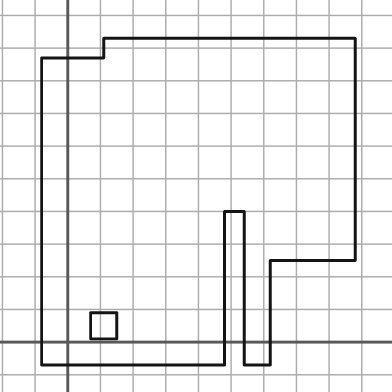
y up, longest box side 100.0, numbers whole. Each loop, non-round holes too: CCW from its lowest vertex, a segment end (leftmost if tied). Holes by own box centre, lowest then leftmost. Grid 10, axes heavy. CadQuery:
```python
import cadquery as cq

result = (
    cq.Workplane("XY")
    .moveTo(-8.0, -7.0)
    .lineTo(48.0, -7.0)
    .lineTo(48.0, 40.0)
    .lineTo(54.0, 40.0)
    .lineTo(54.0, -7.0)
    .lineTo(62.0, -7.0)
    .lineTo(62.0, 25.0)
    .lineTo(88.0, 25.0)
    .lineTo(88.0, 93.0)
    .lineTo(11.0, 93.0)
    .lineTo(11.0, 87.0)
    .lineTo(-8.0, 87.0)
    .close()
    .moveTo(7.0, 1.0)
    .lineTo(15.0, 1.0)
    .lineTo(15.0, 9.0)
    .lineTo(7.0, 9.0)
    .close()
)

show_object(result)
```